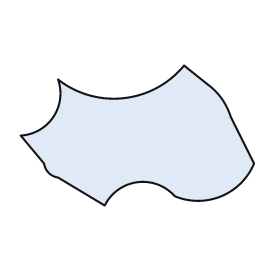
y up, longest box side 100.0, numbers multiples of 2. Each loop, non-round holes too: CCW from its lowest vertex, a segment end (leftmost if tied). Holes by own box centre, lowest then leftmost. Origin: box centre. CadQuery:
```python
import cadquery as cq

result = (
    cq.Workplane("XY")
    .moveTo(-14.0, -30.0)
    .threePointArc((0.0, -20.0), (16.0, -26.0))
    .threePointArc((36.0, -26.0), (50.0, -12.0))
    .lineTo(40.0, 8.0)
    .threePointArc((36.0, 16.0), (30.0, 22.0))
    .lineTo(20.0, 30.0)
    .threePointArc((-6.0, 16.0), (-34.0, 24.0))
    .threePointArc((-36.0, 8.0), (-50.0, 0.0))
    .lineTo(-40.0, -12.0)
    .threePointArc((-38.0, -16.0), (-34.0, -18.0))
    .close()
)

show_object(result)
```